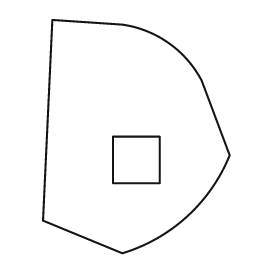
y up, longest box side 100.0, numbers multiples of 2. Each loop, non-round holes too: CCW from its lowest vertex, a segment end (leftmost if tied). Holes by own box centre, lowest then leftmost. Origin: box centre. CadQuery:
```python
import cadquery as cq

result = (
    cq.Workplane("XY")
    .moveTo(-6.0, -50.0)
    .threePointArc((22.0, -34.0), (40.0, -8.0))
    .lineTo(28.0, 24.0)
    .threePointArc((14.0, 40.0), (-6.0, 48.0))
    .lineTo(-36.0, 50.0)
    .lineTo(-40.0, -36.0)
    .close()
    .moveTo(-10.0, -20.0)
    .lineTo(10.0, -20.0)
    .lineTo(10.0, 0.0)
    .lineTo(-10.0, 0.0)
    .close()
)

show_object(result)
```